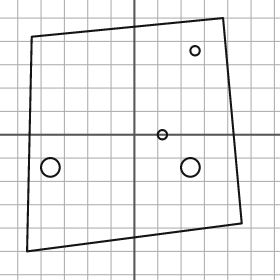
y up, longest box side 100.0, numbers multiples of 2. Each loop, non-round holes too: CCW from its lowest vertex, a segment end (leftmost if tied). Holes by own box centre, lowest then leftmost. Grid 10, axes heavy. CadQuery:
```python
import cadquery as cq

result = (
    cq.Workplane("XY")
    .moveTo(-46.0, -50.0)
    .lineTo(46.0, -38.0)
    .lineTo(38.0, 50.0)
    .lineTo(-44.0, 42.0)
    .close()
    .moveTo(-36.0, -14.0)
    .circle(4.0)
    .moveTo(24.0, -14.0)
    .circle(4.0)
    .moveTo(12.0, 0.0)
    .circle(2.0)
    .moveTo(26.0, 36.0)
    .circle(2.0)
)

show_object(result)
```